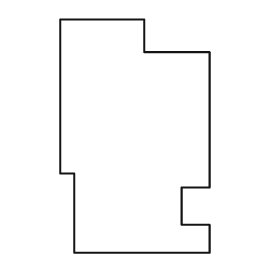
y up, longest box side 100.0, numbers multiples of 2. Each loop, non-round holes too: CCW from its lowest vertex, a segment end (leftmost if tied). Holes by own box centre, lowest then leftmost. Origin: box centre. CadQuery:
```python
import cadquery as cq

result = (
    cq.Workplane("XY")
    .moveTo(-26.0, -50.0)
    .lineTo(32.0, -50.0)
    .lineTo(32.0, -38.0)
    .lineTo(20.0, -38.0)
    .lineTo(20.0, -22.0)
    .lineTo(32.0, -22.0)
    .lineTo(32.0, 36.0)
    .lineTo(4.0, 36.0)
    .lineTo(4.0, 50.0)
    .lineTo(-32.0, 50.0)
    .lineTo(-32.0, -16.0)
    .lineTo(-26.0, -16.0)
    .close()
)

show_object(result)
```